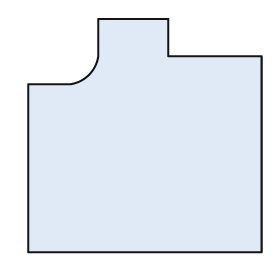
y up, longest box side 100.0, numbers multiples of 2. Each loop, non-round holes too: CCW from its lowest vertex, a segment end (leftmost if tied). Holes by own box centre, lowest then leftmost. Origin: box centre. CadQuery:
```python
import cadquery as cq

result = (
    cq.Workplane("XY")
    .moveTo(-50.0, -50.0)
    .lineTo(50.0, -50.0)
    .lineTo(50.0, 34.0)
    .lineTo(10.0, 34.0)
    .lineTo(10.0, 50.0)
    .lineTo(-20.0, 50.0)
    .lineTo(-20.0, 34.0)
    .threePointArc((-24.0, 26.0), (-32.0, 22.0))
    .lineTo(-50.0, 22.0)
    .close()
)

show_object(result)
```